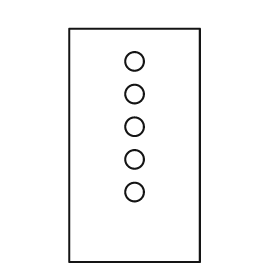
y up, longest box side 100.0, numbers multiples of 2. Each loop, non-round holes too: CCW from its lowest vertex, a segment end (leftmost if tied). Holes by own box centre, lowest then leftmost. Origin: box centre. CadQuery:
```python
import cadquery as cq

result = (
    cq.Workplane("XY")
    .moveTo(-28.0, -50.0)
    .lineTo(28.0, -50.0)
    .lineTo(28.0, 50.0)
    .lineTo(-28.0, 50.0)
    .close()
    .moveTo(0.0, -20.0)
    .circle(4.0)
    .moveTo(0.0, -6.0)
    .circle(4.0)
    .moveTo(0.0, 8.0)
    .circle(4.0)
    .moveTo(0.0, 22.0)
    .circle(4.0)
    .moveTo(0.0, 36.0)
    .circle(4.0)
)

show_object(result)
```